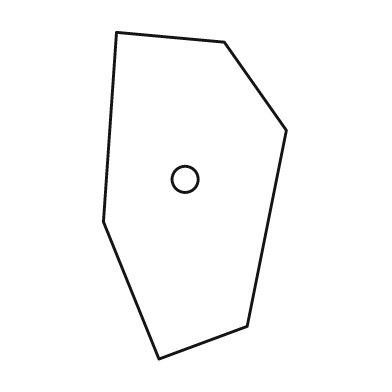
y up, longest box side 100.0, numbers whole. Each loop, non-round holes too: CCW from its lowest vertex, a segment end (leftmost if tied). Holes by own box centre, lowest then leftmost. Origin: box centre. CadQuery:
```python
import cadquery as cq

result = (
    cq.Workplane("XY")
    .moveTo(-11.0, -50.0)
    .lineTo(16.0, -40.0)
    .lineTo(28.0, 20.0)
    .lineTo(9.0, 47.0)
    .lineTo(-24.0, 50.0)
    .lineTo(-28.0, -8.0)
    .close()
    .moveTo(-3.0, 5.0)
    .circle(4.0)
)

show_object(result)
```